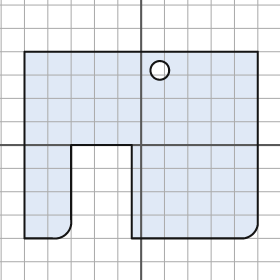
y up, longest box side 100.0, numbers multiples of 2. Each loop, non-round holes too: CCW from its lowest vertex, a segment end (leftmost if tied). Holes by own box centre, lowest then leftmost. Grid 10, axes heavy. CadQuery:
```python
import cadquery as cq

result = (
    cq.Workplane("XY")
    .moveTo(-50.0, -40.0)
    .lineTo(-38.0, -40.0)
    .threePointArc((-32.0, -38.0), (-30.0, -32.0))
    .lineTo(-30.0, 0.0)
    .lineTo(-4.0, 0.0)
    .lineTo(-4.0, -40.0)
    .lineTo(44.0, -40.0)
    .threePointArc((48.0, -38.0), (50.0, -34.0))
    .lineTo(50.0, 40.0)
    .lineTo(-50.0, 40.0)
    .close()
    .moveTo(8.0, 32.0)
    .circle(4.0)
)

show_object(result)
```